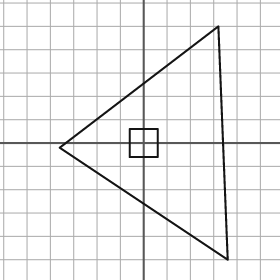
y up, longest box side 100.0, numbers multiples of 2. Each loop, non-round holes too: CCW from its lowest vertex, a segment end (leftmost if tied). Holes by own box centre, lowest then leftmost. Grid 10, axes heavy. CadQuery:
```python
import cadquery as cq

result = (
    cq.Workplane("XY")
    .moveTo(36.0, -50.0)
    .lineTo(32.0, 50.0)
    .lineTo(-36.0, -2.0)
    .close()
    .moveTo(-6.0, -6.0)
    .lineTo(6.0, -6.0)
    .lineTo(6.0, 6.0)
    .lineTo(-6.0, 6.0)
    .close()
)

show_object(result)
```